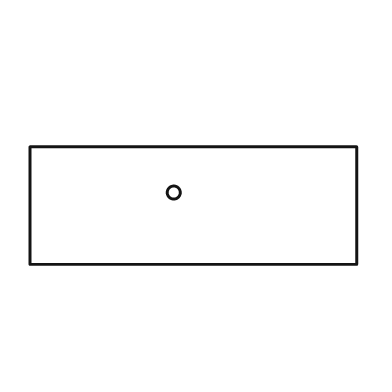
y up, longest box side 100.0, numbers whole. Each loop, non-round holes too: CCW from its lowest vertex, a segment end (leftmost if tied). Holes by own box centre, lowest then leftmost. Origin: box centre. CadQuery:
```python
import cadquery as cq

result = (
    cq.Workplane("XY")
    .moveTo(-50.0, -18.0)
    .lineTo(50.0, -18.0)
    .lineTo(50.0, 18.0)
    .lineTo(-50.0, 18.0)
    .close()
    .moveTo(-6.0, 4.0)
    .circle(2.0)
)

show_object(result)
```